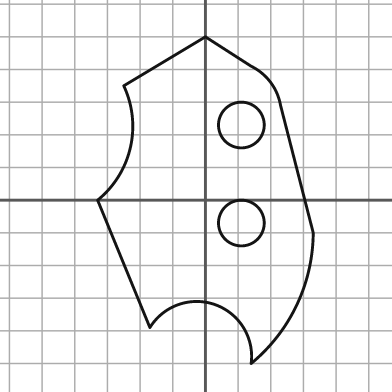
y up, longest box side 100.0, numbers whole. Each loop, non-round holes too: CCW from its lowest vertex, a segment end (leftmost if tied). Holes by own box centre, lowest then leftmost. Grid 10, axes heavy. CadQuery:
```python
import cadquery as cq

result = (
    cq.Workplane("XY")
    .moveTo(14.0, -50.0)
    .threePointArc((28.0, -32.0), (33.0, -10.0))
    .lineTo(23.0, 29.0)
    .threePointArc((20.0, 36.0), (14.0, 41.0))
    .lineTo(0.0, 50.0)
    .lineTo(-25.0, 35.0)
    .threePointArc((-23.0, 16.0), (-33.0, 0.0))
    .lineTo(-17.0, -39.0)
    .threePointArc((3.0, -32.0), (14.0, -50.0))
    .close()
    .moveTo(11.0, -7.0)
    .circle(7.0)
    .moveTo(11.0, 23.0)
    .circle(7.0)
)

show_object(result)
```